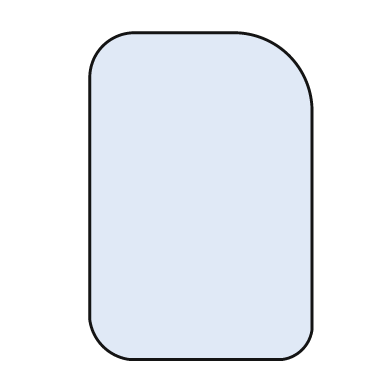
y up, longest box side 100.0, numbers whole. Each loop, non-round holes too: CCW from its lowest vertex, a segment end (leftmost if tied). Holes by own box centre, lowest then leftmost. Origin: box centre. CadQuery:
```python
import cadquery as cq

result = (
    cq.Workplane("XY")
    .moveTo(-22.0, -50.0)
    .lineTo(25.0, -50.0)
    .threePointArc((31.0, -47.0), (34.0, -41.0))
    .lineTo(34.0, 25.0)
    .threePointArc((27.0, 43.0), (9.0, 50.0))
    .lineTo(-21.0, 50.0)
    .threePointArc((-30.0, 46.0), (-34.0, 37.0))
    .lineTo(-34.0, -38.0)
    .threePointArc((-30.0, -46.0), (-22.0, -50.0))
    .close()
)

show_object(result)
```